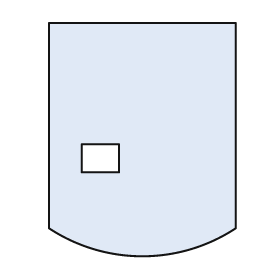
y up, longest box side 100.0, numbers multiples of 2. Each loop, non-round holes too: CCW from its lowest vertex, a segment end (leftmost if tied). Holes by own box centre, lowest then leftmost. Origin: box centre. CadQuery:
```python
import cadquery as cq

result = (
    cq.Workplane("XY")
    .moveTo(-40.0, -38.0)
    .threePointArc((0.0, -50.0), (40.0, -38.0))
    .lineTo(40.0, 50.0)
    .lineTo(-40.0, 50.0)
    .close()
    .moveTo(-26.0, -14.0)
    .lineTo(-10.0, -14.0)
    .lineTo(-10.0, -2.0)
    .lineTo(-26.0, -2.0)
    .close()
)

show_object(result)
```